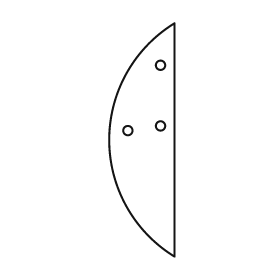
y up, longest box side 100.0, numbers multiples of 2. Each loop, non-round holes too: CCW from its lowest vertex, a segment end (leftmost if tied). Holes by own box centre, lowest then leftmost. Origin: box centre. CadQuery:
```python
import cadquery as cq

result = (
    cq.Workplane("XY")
    .moveTo(14.0, -50.0)
    .lineTo(14.0, 50.0)
    .threePointArc((-14.0, 0.0), (14.0, -50.0))
    .close()
    .moveTo(-6.0, 4.0)
    .circle(2.0)
    .moveTo(8.0, 6.0)
    .circle(2.0)
    .moveTo(8.0, 32.0)
    .circle(2.0)
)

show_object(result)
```